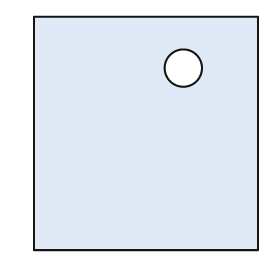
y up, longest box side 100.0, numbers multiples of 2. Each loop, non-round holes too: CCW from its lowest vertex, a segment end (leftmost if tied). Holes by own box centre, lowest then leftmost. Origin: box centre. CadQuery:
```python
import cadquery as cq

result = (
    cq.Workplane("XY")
    .moveTo(-48.0, -50.0)
    .lineTo(48.0, -50.0)
    .lineTo(48.0, 50.0)
    .lineTo(-48.0, 50.0)
    .close()
    .moveTo(16.0, 28.0)
    .circle(8.0)
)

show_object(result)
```